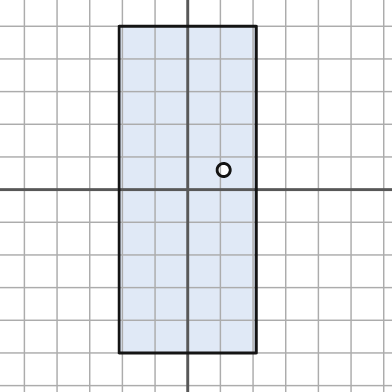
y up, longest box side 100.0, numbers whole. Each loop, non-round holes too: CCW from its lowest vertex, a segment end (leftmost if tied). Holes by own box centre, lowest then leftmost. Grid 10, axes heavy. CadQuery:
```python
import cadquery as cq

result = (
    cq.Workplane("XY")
    .moveTo(-21.0, -50.0)
    .lineTo(21.0, -50.0)
    .lineTo(21.0, 50.0)
    .lineTo(-21.0, 50.0)
    .close()
    .moveTo(11.0, 6.0)
    .circle(2.0)
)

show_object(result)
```